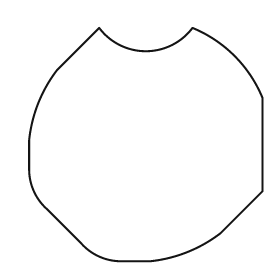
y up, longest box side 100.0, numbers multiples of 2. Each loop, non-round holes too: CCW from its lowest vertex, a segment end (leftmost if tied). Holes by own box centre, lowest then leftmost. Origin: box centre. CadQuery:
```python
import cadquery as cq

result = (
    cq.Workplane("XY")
    .moveTo(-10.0, -50.0)
    .lineTo(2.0, -50.0)
    .threePointArc((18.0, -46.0), (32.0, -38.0))
    .lineTo(50.0, -20.0)
    .lineTo(50.0, 20.0)
    .threePointArc((38.0, 38.0), (20.0, 50.0))
    .threePointArc((0.0, 40.0), (-20.0, 50.0))
    .lineTo(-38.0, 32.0)
    .threePointArc((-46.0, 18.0), (-50.0, 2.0))
    .lineTo(-50.0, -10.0)
    .threePointArc((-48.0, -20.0), (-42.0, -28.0))
    .lineTo(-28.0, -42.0)
    .threePointArc((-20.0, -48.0), (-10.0, -50.0))
    .close()
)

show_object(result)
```